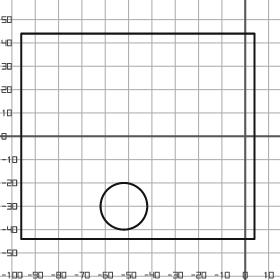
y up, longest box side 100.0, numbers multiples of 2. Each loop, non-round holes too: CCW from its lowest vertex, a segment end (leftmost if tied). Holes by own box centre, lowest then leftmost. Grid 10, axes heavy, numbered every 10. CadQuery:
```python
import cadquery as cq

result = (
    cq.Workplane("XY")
    .moveTo(-96.0, -44.0)
    .lineTo(4.0, -44.0)
    .lineTo(4.0, 44.0)
    .lineTo(-96.0, 44.0)
    .close()
    .moveTo(-52.0, -30.0)
    .circle(10.0)
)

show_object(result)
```